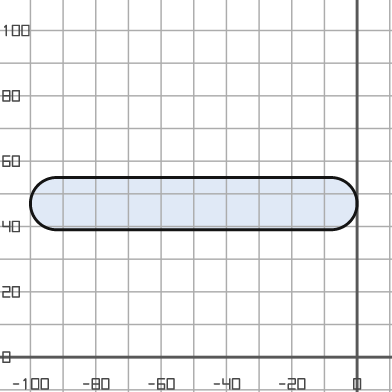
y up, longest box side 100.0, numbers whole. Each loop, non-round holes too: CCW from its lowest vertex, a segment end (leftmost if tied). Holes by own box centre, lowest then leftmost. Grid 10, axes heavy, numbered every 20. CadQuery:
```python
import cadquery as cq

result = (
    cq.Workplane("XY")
    .moveTo(-92.0, 39.0)
    .lineTo(-8.0, 39.0)
    .threePointArc((0.0, 47.0), (-8.0, 55.0))
    .lineTo(-92.0, 55.0)
    .threePointArc((-100.0, 47.0), (-92.0, 39.0))
    .close()
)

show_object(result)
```